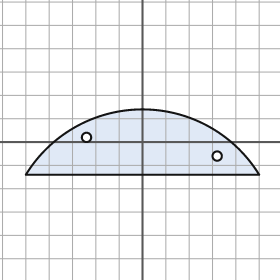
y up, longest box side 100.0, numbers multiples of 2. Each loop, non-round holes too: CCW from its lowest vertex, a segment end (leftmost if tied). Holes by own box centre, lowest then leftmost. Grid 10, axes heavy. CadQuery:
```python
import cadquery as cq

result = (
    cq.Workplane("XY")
    .moveTo(-50.0, -14.0)
    .lineTo(50.0, -14.0)
    .threePointArc((0.0, 14.0), (-50.0, -14.0))
    .close()
    .moveTo(32.0, -6.0)
    .circle(2.0)
    .moveTo(-24.0, 2.0)
    .circle(2.0)
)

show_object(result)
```